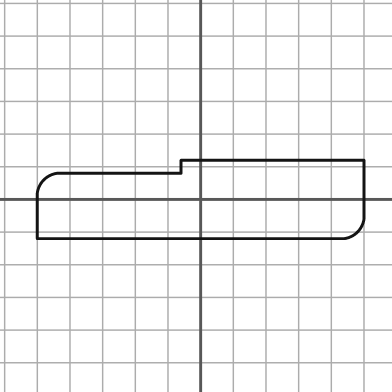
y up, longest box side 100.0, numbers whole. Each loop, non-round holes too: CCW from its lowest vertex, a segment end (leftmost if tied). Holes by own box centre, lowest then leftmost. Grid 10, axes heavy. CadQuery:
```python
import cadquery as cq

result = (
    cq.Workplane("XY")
    .moveTo(-50.0, -12.0)
    .lineTo(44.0, -12.0)
    .threePointArc((48.0, -10.0), (50.0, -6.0))
    .lineTo(50.0, 12.0)
    .lineTo(-6.0, 12.0)
    .lineTo(-6.0, 8.0)
    .lineTo(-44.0, 8.0)
    .threePointArc((-48.0, 6.0), (-50.0, 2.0))
    .close()
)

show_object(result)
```